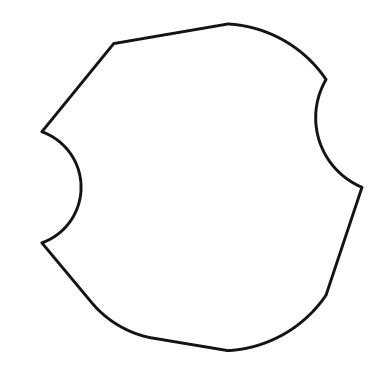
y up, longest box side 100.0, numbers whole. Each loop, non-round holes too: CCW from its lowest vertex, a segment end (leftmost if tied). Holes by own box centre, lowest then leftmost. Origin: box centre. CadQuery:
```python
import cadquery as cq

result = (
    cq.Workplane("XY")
    .moveTo(8.0, -50.0)
    .threePointArc((25.0, -45.0), (38.0, -33.0))
    .lineTo(49.0, 0.0)
    .threePointArc((36.0, 14.0), (38.0, 33.0))
    .threePointArc((25.0, 45.0), (8.0, 50.0))
    .lineTo(-27.0, 44.0)
    .lineTo(-49.0, 17.0)
    .threePointArc((-37.0, 0.0), (-49.0, -17.0))
    .lineTo(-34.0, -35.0)
    .threePointArc((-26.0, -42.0), (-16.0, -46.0))
    .close()
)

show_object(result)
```